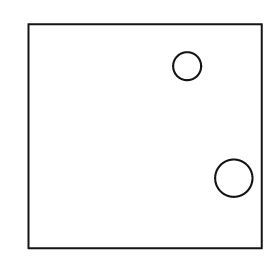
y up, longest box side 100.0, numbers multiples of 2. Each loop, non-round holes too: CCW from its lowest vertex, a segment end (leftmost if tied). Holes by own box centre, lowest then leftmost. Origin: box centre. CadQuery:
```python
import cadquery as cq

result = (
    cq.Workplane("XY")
    .moveTo(-50.0, -48.0)
    .lineTo(50.0, -48.0)
    .lineTo(50.0, 48.0)
    .lineTo(-50.0, 48.0)
    .close()
    .moveTo(38.0, -18.0)
    .circle(8.0)
    .moveTo(18.0, 30.0)
    .circle(6.0)
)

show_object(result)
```